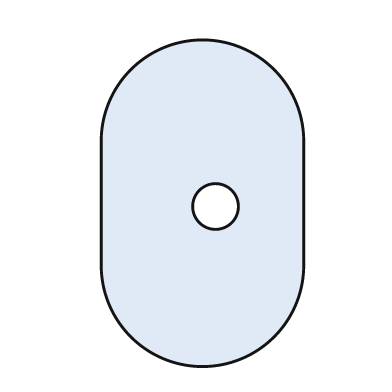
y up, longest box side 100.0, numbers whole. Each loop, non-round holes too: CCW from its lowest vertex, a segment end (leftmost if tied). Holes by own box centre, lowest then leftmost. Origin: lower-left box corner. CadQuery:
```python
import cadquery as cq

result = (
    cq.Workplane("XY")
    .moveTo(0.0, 31.0)
    .threePointArc((31.0, 0.0), (62.0, 31.0))
    .lineTo(62.0, 69.0)
    .threePointArc((31.0, 100.0), (0.0, 69.0))
    .close()
    .moveTo(35.0, 49.0)
    .circle(7.0)
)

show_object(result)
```